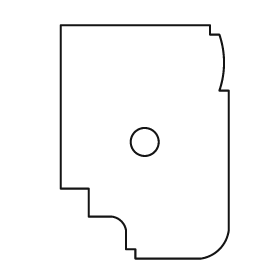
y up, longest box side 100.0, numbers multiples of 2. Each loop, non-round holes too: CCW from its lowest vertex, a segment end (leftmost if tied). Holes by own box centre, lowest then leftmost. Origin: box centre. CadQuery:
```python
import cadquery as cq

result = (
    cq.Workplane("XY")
    .moveTo(-4.0, -50.0)
    .lineTo(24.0, -50.0)
    .threePointArc((32.0, -46.0), (36.0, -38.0))
    .lineTo(36.0, 22.0)
    .lineTo(32.0, 22.0)
    .threePointArc((34.0, 34.0), (32.0, 46.0))
    .lineTo(28.0, 46.0)
    .lineTo(28.0, 50.0)
    .lineTo(-36.0, 50.0)
    .lineTo(-36.0, -20.0)
    .lineTo(-24.0, -20.0)
    .lineTo(-24.0, -32.0)
    .lineTo(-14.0, -32.0)
    .threePointArc((-10.0, -34.0), (-8.0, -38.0))
    .lineTo(-8.0, -46.0)
    .lineTo(-4.0, -46.0)
    .close()
    .moveTo(0.0, 0.0)
    .circle(6.0)
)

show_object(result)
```